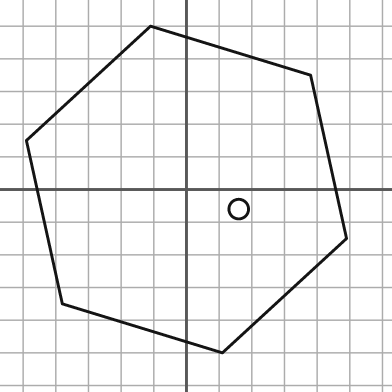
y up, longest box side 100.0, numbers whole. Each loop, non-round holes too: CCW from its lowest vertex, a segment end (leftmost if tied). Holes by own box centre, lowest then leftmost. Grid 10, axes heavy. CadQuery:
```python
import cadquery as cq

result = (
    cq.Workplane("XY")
    .moveTo(11.0, -50.0)
    .lineTo(49.0, -15.0)
    .lineTo(38.0, 35.0)
    .lineTo(-11.0, 50.0)
    .lineTo(-49.0, 15.0)
    .lineTo(-38.0, -35.0)
    .close()
    .moveTo(16.0, -6.0)
    .circle(3.0)
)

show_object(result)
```